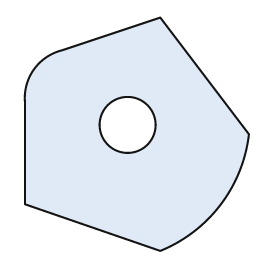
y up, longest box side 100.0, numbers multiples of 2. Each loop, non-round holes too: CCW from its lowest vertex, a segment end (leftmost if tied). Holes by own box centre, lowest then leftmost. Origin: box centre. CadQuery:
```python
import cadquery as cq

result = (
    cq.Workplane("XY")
    .moveTo(10.0, -50.0)
    .threePointArc((36.0, -30.0), (48.0, 0.0))
    .lineTo(10.0, 50.0)
    .lineTo(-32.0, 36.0)
    .threePointArc((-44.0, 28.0), (-48.0, 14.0))
    .lineTo(-48.0, -30.0)
    .close()
    .moveTo(-4.0, 4.0)
    .circle(12.0)
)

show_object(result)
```